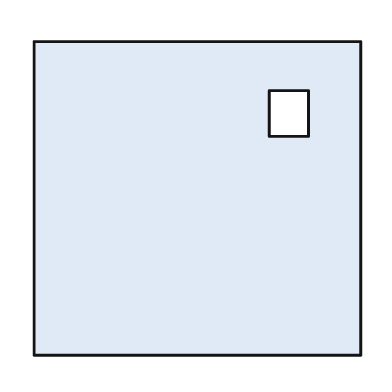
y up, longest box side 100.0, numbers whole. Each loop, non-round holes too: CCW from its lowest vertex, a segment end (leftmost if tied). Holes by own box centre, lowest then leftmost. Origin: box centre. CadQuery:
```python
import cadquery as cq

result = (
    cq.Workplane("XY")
    .moveTo(-50.0, -48.0)
    .lineTo(50.0, -48.0)
    .lineTo(50.0, 48.0)
    .lineTo(-50.0, 48.0)
    .close()
    .moveTo(22.0, 19.0)
    .lineTo(34.0, 19.0)
    .lineTo(34.0, 33.0)
    .lineTo(22.0, 33.0)
    .close()
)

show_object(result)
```